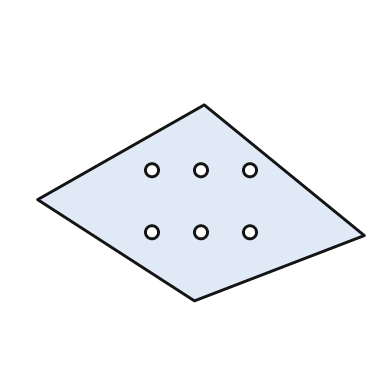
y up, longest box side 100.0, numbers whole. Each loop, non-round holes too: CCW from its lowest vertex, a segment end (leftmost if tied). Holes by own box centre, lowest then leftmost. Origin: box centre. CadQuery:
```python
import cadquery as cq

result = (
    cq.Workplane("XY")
    .moveTo(-2.0, -30.0)
    .lineTo(50.0, -10.0)
    .lineTo(1.0, 30.0)
    .lineTo(-50.0, 1.0)
    .close()
    .moveTo(-15.0, -9.0)
    .circle(2.0)
    .moveTo(0.0, -9.0)
    .circle(2.0)
    .moveTo(15.0, -9.0)
    .circle(2.0)
    .moveTo(-15.0, 10.0)
    .circle(2.0)
    .moveTo(0.0, 10.0)
    .circle(2.0)
    .moveTo(15.0, 10.0)
    .circle(2.0)
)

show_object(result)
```